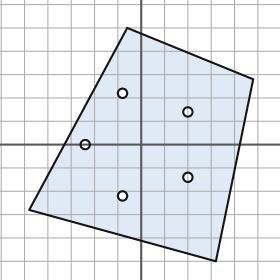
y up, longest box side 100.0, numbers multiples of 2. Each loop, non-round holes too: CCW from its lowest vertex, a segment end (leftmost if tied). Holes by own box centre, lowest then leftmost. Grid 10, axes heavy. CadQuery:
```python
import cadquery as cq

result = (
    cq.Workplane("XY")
    .moveTo(32.0, -50.0)
    .lineTo(48.0, 28.0)
    .lineTo(-6.0, 50.0)
    .lineTo(-48.0, -28.0)
    .close()
    .moveTo(-8.0, -22.0)
    .circle(2.0)
    .moveTo(20.0, -14.0)
    .circle(2.0)
    .moveTo(-24.0, 0.0)
    .circle(2.0)
    .moveTo(20.0, 14.0)
    .circle(2.0)
    .moveTo(-8.0, 22.0)
    .circle(2.0)
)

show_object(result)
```